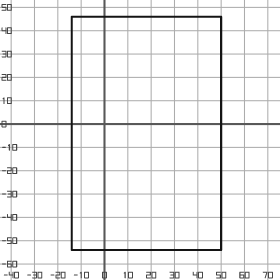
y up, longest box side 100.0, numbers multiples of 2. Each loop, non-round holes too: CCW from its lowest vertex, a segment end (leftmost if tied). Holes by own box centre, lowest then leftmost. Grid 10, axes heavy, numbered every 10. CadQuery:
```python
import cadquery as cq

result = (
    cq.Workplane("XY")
    .moveTo(-14.0, -54.0)
    .lineTo(50.0, -54.0)
    .lineTo(50.0, 46.0)
    .lineTo(-14.0, 46.0)
    .close()
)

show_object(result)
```